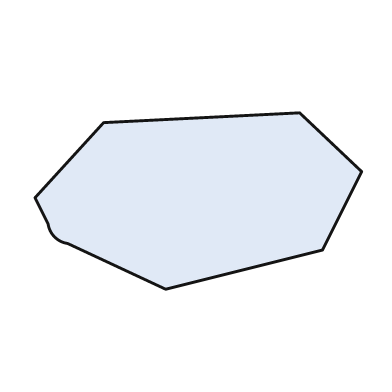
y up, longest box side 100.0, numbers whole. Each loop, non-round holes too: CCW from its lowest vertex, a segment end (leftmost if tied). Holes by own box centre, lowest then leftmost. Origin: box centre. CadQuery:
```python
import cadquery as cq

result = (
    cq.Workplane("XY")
    .moveTo(-10.0, -27.0)
    .lineTo(38.0, -15.0)
    .lineTo(50.0, 9.0)
    .lineTo(31.0, 27.0)
    .lineTo(-29.0, 24.0)
    .lineTo(-50.0, 1.0)
    .lineTo(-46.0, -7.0)
    .threePointArc((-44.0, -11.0), (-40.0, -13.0))
    .close()
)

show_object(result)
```